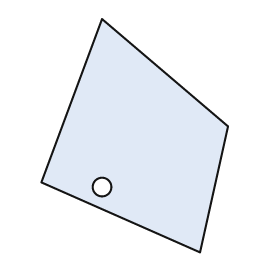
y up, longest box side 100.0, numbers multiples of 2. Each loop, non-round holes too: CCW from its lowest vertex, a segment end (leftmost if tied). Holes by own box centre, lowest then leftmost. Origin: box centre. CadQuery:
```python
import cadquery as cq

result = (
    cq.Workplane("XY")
    .moveTo(28.0, -50.0)
    .lineTo(40.0, 4.0)
    .lineTo(-14.0, 50.0)
    .lineTo(-40.0, -20.0)
    .close()
    .moveTo(-14.0, -22.0)
    .circle(4.0)
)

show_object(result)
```